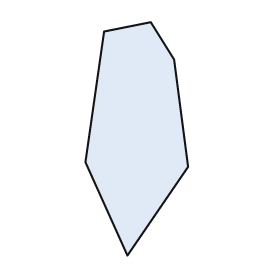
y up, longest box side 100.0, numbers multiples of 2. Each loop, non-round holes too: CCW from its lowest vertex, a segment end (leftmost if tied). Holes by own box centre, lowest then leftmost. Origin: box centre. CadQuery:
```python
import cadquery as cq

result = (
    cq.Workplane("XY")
    .moveTo(-4.0, -50.0)
    .lineTo(22.0, -12.0)
    .lineTo(16.0, 34.0)
    .lineTo(6.0, 50.0)
    .lineTo(-14.0, 46.0)
    .lineTo(-22.0, -10.0)
    .close()
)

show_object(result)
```